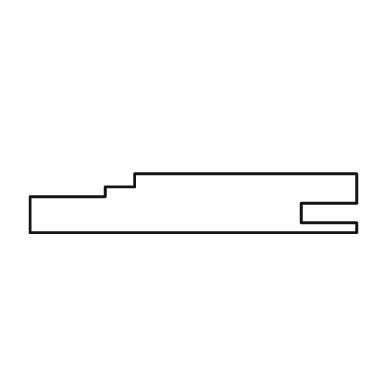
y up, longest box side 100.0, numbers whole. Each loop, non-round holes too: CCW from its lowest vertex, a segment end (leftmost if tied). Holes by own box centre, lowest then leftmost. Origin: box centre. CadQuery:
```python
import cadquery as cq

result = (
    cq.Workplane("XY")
    .moveTo(-50.0, -9.0)
    .lineTo(50.0, -9.0)
    .lineTo(50.0, -6.0)
    .lineTo(33.0, -6.0)
    .lineTo(33.0, 0.0)
    .lineTo(50.0, 0.0)
    .lineTo(50.0, 9.0)
    .lineTo(-18.0, 9.0)
    .lineTo(-18.0, 5.0)
    .lineTo(-27.0, 5.0)
    .lineTo(-27.0, 2.0)
    .lineTo(-50.0, 2.0)
    .close()
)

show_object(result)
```